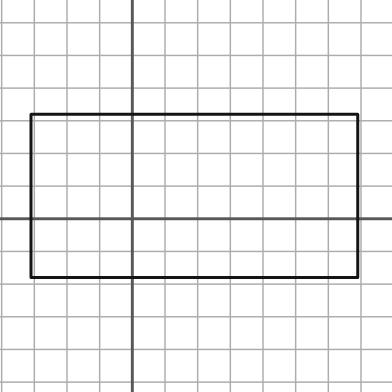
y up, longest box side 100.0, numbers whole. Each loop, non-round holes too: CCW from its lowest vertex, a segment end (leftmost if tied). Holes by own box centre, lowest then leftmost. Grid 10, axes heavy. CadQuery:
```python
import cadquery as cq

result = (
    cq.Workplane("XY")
    .moveTo(-31.0, -18.0)
    .lineTo(69.0, -18.0)
    .lineTo(69.0, 32.0)
    .lineTo(-31.0, 32.0)
    .close()
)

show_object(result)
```